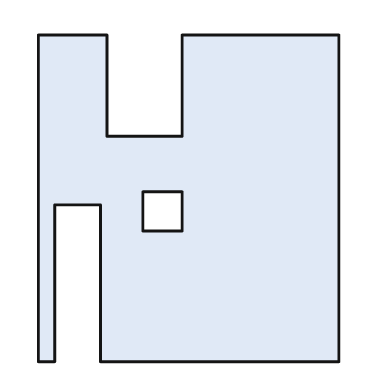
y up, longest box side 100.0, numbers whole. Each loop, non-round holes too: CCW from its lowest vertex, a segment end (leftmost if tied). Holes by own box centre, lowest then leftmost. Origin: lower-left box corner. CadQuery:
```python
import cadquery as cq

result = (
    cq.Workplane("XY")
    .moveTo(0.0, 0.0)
    .lineTo(5.0, 0.0)
    .lineTo(5.0, 48.0)
    .lineTo(19.0, 48.0)
    .lineTo(19.0, 0.0)
    .lineTo(92.0, 0.0)
    .lineTo(92.0, 100.0)
    .lineTo(44.0, 100.0)
    .lineTo(44.0, 69.0)
    .lineTo(21.0, 69.0)
    .lineTo(21.0, 100.0)
    .lineTo(0.0, 100.0)
    .close()
    .moveTo(32.0, 40.0)
    .lineTo(44.0, 40.0)
    .lineTo(44.0, 52.0)
    .lineTo(32.0, 52.0)
    .close()
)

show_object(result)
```